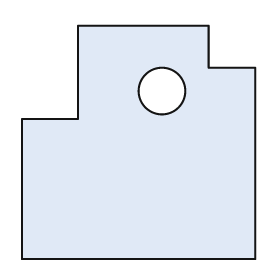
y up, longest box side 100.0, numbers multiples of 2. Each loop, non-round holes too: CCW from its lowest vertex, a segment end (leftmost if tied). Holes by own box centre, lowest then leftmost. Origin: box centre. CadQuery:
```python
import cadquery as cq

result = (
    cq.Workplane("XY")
    .moveTo(-50.0, -50.0)
    .lineTo(50.0, -50.0)
    .lineTo(50.0, 32.0)
    .lineTo(30.0, 32.0)
    .lineTo(30.0, 50.0)
    .lineTo(-26.0, 50.0)
    .lineTo(-26.0, 10.0)
    .lineTo(-50.0, 10.0)
    .close()
    .moveTo(10.0, 22.0)
    .circle(10.0)
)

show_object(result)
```